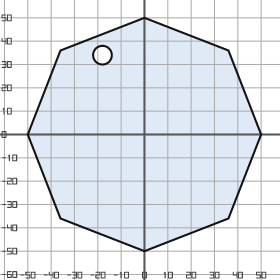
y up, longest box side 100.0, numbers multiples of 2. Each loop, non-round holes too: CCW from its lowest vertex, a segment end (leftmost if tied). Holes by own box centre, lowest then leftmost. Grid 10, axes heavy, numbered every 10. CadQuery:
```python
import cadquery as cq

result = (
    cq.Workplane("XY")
    .moveTo(0.0, -50.0)
    .lineTo(36.0, -36.0)
    .lineTo(50.0, 0.0)
    .lineTo(36.0, 36.0)
    .lineTo(0.0, 50.0)
    .lineTo(-36.0, 36.0)
    .lineTo(-50.0, 0.0)
    .lineTo(-36.0, -36.0)
    .close()
    .moveTo(-18.0, 34.0)
    .circle(4.0)
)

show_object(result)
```